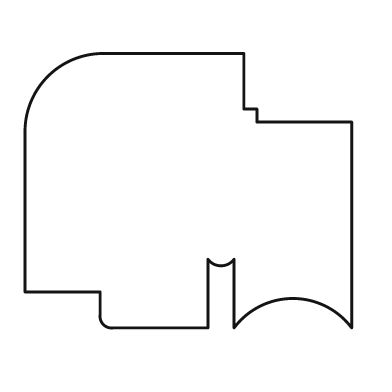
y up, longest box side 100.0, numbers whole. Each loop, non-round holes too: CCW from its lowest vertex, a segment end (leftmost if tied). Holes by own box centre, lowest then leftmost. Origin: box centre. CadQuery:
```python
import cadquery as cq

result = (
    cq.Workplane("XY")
    .moveTo(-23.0, -42.0)
    .lineTo(6.0, -42.0)
    .lineTo(6.0, -21.0)
    .threePointArc((10.0, -23.0), (14.0, -21.0))
    .lineTo(14.0, -42.0)
    .threePointArc((32.0, -33.0), (50.0, -42.0))
    .lineTo(50.0, 21.0)
    .lineTo(21.0, 21.0)
    .lineTo(21.0, 25.0)
    .lineTo(17.0, 25.0)
    .lineTo(17.0, 42.0)
    .lineTo(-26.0, 42.0)
    .threePointArc((-43.0, 35.0), (-50.0, 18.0))
    .lineTo(-50.0, -31.0)
    .lineTo(-27.0, -31.0)
    .lineTo(-27.0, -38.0)
    .threePointArc((-26.0, -41.0), (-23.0, -42.0))
    .close()
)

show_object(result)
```